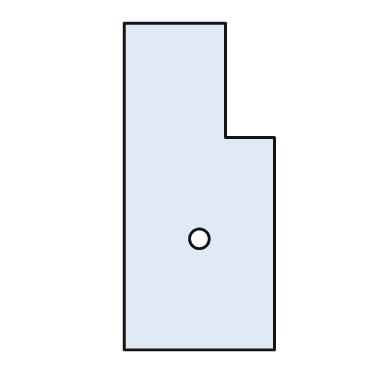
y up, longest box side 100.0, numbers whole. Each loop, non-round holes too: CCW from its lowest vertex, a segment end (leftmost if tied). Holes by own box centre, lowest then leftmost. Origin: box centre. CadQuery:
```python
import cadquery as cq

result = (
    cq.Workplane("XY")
    .moveTo(-23.0, -50.0)
    .lineTo(23.0, -50.0)
    .lineTo(23.0, 15.0)
    .lineTo(8.0, 15.0)
    .lineTo(8.0, 50.0)
    .lineTo(-23.0, 50.0)
    .close()
    .moveTo(0.0, -16.0)
    .circle(3.0)
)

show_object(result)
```